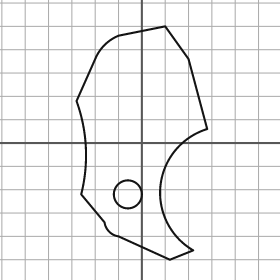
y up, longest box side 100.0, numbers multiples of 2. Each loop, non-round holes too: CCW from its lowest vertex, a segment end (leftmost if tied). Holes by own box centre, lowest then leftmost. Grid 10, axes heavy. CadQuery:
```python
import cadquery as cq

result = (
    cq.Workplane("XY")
    .moveTo(12.0, -50.0)
    .lineTo(22.0, -46.0)
    .threePointArc((8.0, -18.0), (28.0, 6.0))
    .lineTo(20.0, 36.0)
    .lineTo(10.0, 50.0)
    .lineTo(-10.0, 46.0)
    .threePointArc((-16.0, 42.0), (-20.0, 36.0))
    .lineTo(-28.0, 18.0)
    .threePointArc((-24.0, -2.0), (-26.0, -22.0))
    .lineTo(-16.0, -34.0)
    .threePointArc((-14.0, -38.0), (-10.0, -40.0))
    .close()
    .moveTo(-6.0, -22.0)
    .circle(6.0)
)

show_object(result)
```